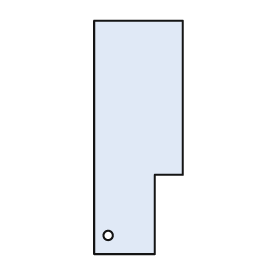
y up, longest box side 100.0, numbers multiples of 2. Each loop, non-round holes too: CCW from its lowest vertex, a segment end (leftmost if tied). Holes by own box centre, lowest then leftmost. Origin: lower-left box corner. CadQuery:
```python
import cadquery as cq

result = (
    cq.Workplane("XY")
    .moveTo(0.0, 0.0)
    .lineTo(26.0, 0.0)
    .lineTo(26.0, 34.0)
    .lineTo(38.0, 34.0)
    .lineTo(38.0, 100.0)
    .lineTo(0.0, 100.0)
    .close()
    .moveTo(6.0, 8.0)
    .circle(2.0)
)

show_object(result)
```